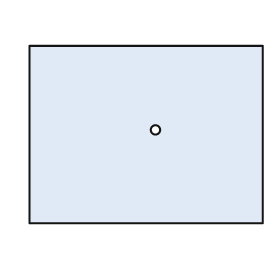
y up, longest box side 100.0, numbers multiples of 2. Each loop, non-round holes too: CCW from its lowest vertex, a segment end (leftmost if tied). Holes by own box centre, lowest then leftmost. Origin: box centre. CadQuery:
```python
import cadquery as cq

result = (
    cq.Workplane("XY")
    .moveTo(-50.0, -38.0)
    .lineTo(50.0, -38.0)
    .lineTo(50.0, 38.0)
    .lineTo(-50.0, 38.0)
    .close()
    .moveTo(4.0, 2.0)
    .circle(2.0)
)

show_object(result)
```